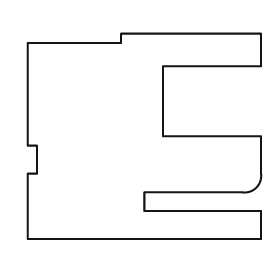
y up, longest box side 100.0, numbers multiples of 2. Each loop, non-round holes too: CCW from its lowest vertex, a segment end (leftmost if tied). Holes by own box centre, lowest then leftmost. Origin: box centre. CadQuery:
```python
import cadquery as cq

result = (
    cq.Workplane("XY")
    .moveTo(-50.0, -44.0)
    .lineTo(50.0, -44.0)
    .lineTo(50.0, -32.0)
    .lineTo(0.0, -32.0)
    .lineTo(0.0, -24.0)
    .lineTo(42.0, -24.0)
    .threePointArc((48.0, -22.0), (50.0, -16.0))
    .lineTo(50.0, 0.0)
    .lineTo(8.0, 0.0)
    .lineTo(8.0, 30.0)
    .lineTo(50.0, 30.0)
    .lineTo(50.0, 44.0)
    .lineTo(-10.0, 44.0)
    .lineTo(-10.0, 40.0)
    .lineTo(-50.0, 40.0)
    .lineTo(-50.0, -4.0)
    .lineTo(-46.0, -4.0)
    .lineTo(-46.0, -16.0)
    .lineTo(-50.0, -16.0)
    .close()
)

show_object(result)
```